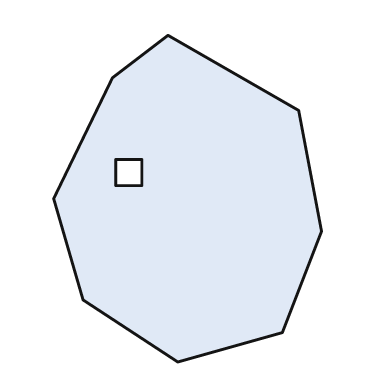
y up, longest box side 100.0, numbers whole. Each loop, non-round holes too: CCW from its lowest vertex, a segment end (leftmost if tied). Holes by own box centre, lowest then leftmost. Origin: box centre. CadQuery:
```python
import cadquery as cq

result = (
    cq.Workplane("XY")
    .moveTo(-3.0, -50.0)
    .lineTo(29.0, -41.0)
    .lineTo(41.0, -10.0)
    .lineTo(34.0, 27.0)
    .lineTo(-6.0, 50.0)
    .lineTo(-23.0, 37.0)
    .lineTo(-41.0, 0.0)
    .lineTo(-32.0, -31.0)
    .close()
    .moveTo(-22.0, 4.0)
    .lineTo(-14.0, 4.0)
    .lineTo(-14.0, 12.0)
    .lineTo(-22.0, 12.0)
    .close()
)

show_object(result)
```